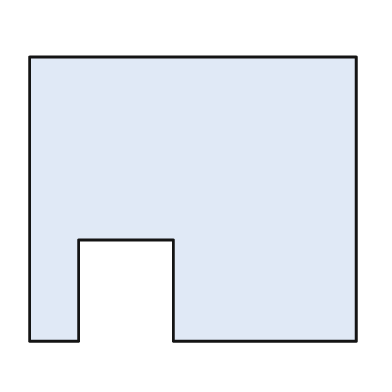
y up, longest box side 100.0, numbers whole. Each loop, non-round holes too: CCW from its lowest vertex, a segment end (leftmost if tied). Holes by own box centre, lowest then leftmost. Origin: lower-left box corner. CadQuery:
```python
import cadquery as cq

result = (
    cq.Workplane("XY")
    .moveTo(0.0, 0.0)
    .lineTo(15.0, 0.0)
    .lineTo(15.0, 31.0)
    .lineTo(44.0, 31.0)
    .lineTo(44.0, 0.0)
    .lineTo(100.0, 0.0)
    .lineTo(100.0, 87.0)
    .lineTo(0.0, 87.0)
    .close()
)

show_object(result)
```